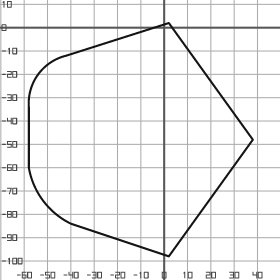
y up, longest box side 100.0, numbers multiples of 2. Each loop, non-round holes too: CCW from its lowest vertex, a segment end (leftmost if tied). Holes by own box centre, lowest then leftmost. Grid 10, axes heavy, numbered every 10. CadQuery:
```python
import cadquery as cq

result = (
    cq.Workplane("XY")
    .moveTo(2.0, -98.0)
    .lineTo(38.0, -48.0)
    .lineTo(2.0, 2.0)
    .lineTo(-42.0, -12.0)
    .threePointArc((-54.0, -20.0), (-58.0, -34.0))
    .lineTo(-58.0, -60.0)
    .threePointArc((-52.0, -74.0), (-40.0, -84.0))
    .close()
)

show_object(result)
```